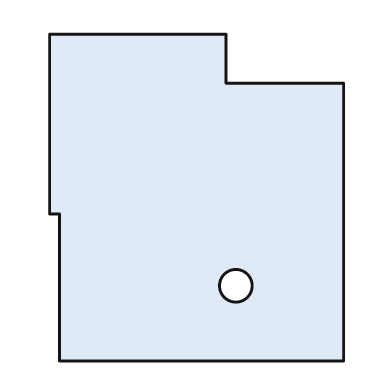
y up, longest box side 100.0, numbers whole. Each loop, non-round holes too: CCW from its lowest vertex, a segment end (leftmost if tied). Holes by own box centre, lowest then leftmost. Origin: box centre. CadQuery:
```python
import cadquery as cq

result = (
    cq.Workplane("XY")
    .moveTo(-42.0, -50.0)
    .lineTo(45.0, -50.0)
    .lineTo(45.0, 35.0)
    .lineTo(9.0, 35.0)
    .lineTo(9.0, 50.0)
    .lineTo(-45.0, 50.0)
    .lineTo(-45.0, -5.0)
    .lineTo(-42.0, -5.0)
    .close()
    .moveTo(12.0, -27.0)
    .circle(5.0)
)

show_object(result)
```